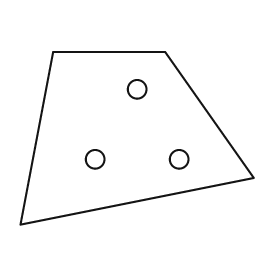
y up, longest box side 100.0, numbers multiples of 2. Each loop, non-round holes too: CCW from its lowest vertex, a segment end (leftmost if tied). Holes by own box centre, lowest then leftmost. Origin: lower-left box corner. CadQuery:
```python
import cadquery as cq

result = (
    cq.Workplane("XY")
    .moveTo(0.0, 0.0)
    .lineTo(100.0, 20.0)
    .lineTo(62.0, 74.0)
    .lineTo(14.0, 74.0)
    .close()
    .moveTo(32.0, 28.0)
    .circle(4.0)
    .moveTo(68.0, 28.0)
    .circle(4.0)
    .moveTo(50.0, 58.0)
    .circle(4.0)
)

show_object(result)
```